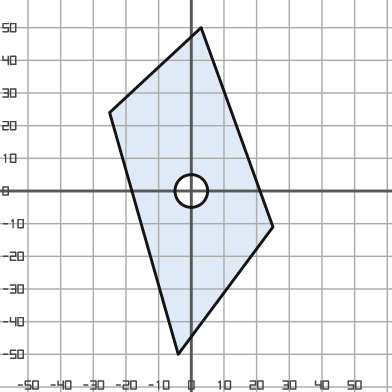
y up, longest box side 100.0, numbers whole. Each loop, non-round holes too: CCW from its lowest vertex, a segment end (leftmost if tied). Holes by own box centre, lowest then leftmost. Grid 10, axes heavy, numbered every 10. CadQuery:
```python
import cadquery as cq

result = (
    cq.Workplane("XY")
    .moveTo(-4.0, -50.0)
    .lineTo(25.0, -11.0)
    .lineTo(3.0, 50.0)
    .lineTo(-25.0, 24.0)
    .close()
    .moveTo(0.0, 0.0)
    .circle(5.0)
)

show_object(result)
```